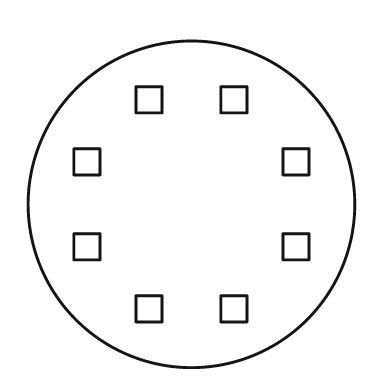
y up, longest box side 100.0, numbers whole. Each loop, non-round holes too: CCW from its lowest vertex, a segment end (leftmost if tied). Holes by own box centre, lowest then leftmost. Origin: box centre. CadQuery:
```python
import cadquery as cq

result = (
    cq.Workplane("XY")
    .moveTo(0.0, 0.0)
    .circle(50.0)
    .moveTo(-17.0, -36.0)
    .lineTo(-9.0, -36.0)
    .lineTo(-9.0, -28.0)
    .lineTo(-17.0, -28.0)
    .close()
    .moveTo(9.0, -36.0)
    .lineTo(17.0, -36.0)
    .lineTo(17.0, -28.0)
    .lineTo(9.0, -28.0)
    .close()
    .moveTo(-36.0, -17.0)
    .lineTo(-28.0, -17.0)
    .lineTo(-28.0, -9.0)
    .lineTo(-36.0, -9.0)
    .close()
    .moveTo(28.0, -17.0)
    .lineTo(36.0, -17.0)
    .lineTo(36.0, -9.0)
    .lineTo(28.0, -9.0)
    .close()
    .moveTo(-36.0, 9.0)
    .lineTo(-28.0, 9.0)
    .lineTo(-28.0, 17.0)
    .lineTo(-36.0, 17.0)
    .close()
    .moveTo(28.0, 9.0)
    .lineTo(36.0, 9.0)
    .lineTo(36.0, 17.0)
    .lineTo(28.0, 17.0)
    .close()
    .moveTo(-17.0, 28.0)
    .lineTo(-9.0, 28.0)
    .lineTo(-9.0, 36.0)
    .lineTo(-17.0, 36.0)
    .close()
    .moveTo(9.0, 28.0)
    .lineTo(17.0, 28.0)
    .lineTo(17.0, 36.0)
    .lineTo(9.0, 36.0)
    .close()
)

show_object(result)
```